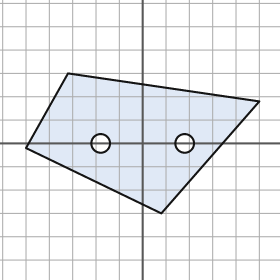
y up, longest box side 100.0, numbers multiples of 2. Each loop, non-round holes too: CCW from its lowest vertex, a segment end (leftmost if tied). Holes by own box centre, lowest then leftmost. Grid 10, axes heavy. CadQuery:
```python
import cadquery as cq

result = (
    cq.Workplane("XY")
    .moveTo(8.0, -30.0)
    .lineTo(50.0, 18.0)
    .lineTo(-32.0, 30.0)
    .lineTo(-50.0, -2.0)
    .close()
    .moveTo(-18.0, 0.0)
    .circle(4.0)
    .moveTo(18.0, 0.0)
    .circle(4.0)
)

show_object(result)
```